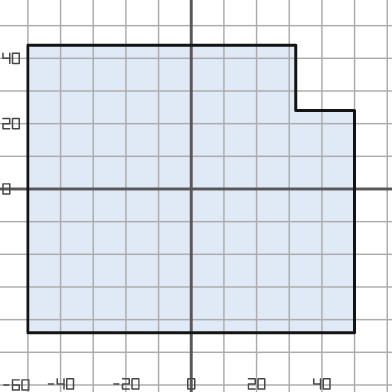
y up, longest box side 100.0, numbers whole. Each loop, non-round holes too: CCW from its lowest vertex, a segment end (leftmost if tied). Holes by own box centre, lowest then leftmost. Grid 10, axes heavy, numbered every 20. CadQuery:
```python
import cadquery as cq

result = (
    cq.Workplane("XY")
    .moveTo(-50.0, -44.0)
    .lineTo(50.0, -44.0)
    .lineTo(50.0, 24.0)
    .lineTo(32.0, 24.0)
    .lineTo(32.0, 44.0)
    .lineTo(-50.0, 44.0)
    .close()
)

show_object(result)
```